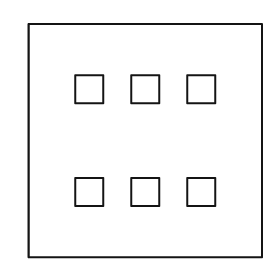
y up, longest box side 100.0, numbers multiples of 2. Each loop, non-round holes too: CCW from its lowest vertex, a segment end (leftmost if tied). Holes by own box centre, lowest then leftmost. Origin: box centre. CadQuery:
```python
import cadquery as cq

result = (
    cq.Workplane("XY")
    .moveTo(-50.0, -50.0)
    .lineTo(50.0, -50.0)
    .lineTo(50.0, 50.0)
    .lineTo(-50.0, 50.0)
    .close()
    .moveTo(-30.0, -28.0)
    .lineTo(-18.0, -28.0)
    .lineTo(-18.0, -16.0)
    .lineTo(-30.0, -16.0)
    .close()
    .moveTo(-6.0, -28.0)
    .lineTo(6.0, -28.0)
    .lineTo(6.0, -16.0)
    .lineTo(-6.0, -16.0)
    .close()
    .moveTo(18.0, -28.0)
    .lineTo(30.0, -28.0)
    .lineTo(30.0, -16.0)
    .lineTo(18.0, -16.0)
    .close()
    .moveTo(-30.0, 16.0)
    .lineTo(-18.0, 16.0)
    .lineTo(-18.0, 28.0)
    .lineTo(-30.0, 28.0)
    .close()
    .moveTo(-6.0, 16.0)
    .lineTo(6.0, 16.0)
    .lineTo(6.0, 28.0)
    .lineTo(-6.0, 28.0)
    .close()
    .moveTo(18.0, 16.0)
    .lineTo(30.0, 16.0)
    .lineTo(30.0, 28.0)
    .lineTo(18.0, 28.0)
    .close()
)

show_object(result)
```